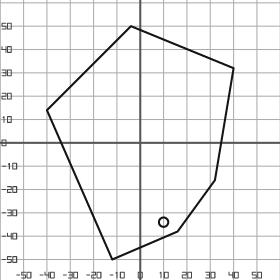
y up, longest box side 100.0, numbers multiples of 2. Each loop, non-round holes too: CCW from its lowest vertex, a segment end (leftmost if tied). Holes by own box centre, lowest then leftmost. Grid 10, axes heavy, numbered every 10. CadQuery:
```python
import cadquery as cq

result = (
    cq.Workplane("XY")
    .moveTo(-12.0, -50.0)
    .lineTo(16.0, -38.0)
    .lineTo(32.0, -16.0)
    .lineTo(40.0, 32.0)
    .lineTo(-4.0, 50.0)
    .lineTo(-40.0, 14.0)
    .close()
    .moveTo(10.0, -34.0)
    .circle(2.0)
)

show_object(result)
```